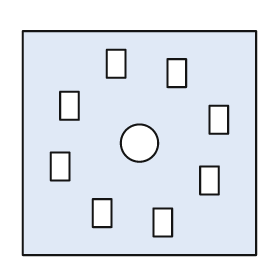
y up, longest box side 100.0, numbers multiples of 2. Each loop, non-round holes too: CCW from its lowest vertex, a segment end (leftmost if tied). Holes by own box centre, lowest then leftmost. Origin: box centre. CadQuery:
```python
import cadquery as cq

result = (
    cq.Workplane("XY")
    .moveTo(-50.0, -48.0)
    .lineTo(50.0, -48.0)
    .lineTo(50.0, 48.0)
    .lineTo(-50.0, 48.0)
    .close()
    .moveTo(6.0, -40.0)
    .lineTo(14.0, -40.0)
    .lineTo(14.0, -28.0)
    .lineTo(6.0, -28.0)
    .close()
    .moveTo(-20.0, -36.0)
    .lineTo(-12.0, -36.0)
    .lineTo(-12.0, -24.0)
    .lineTo(-20.0, -24.0)
    .close()
    .moveTo(26.0, -22.0)
    .lineTo(34.0, -22.0)
    .lineTo(34.0, -10.0)
    .lineTo(26.0, -10.0)
    .close()
    .moveTo(-38.0, -16.0)
    .lineTo(-30.0, -16.0)
    .lineTo(-30.0, -4.0)
    .lineTo(-38.0, -4.0)
    .close()
    .moveTo(0.0, 0.0)
    .circle(8.0)
    .moveTo(30.0, 4.0)
    .lineTo(38.0, 4.0)
    .lineTo(38.0, 16.0)
    .lineTo(30.0, 16.0)
    .close()
    .moveTo(-34.0, 10.0)
    .lineTo(-26.0, 10.0)
    .lineTo(-26.0, 22.0)
    .lineTo(-34.0, 22.0)
    .close()
    .moveTo(12.0, 24.0)
    .lineTo(20.0, 24.0)
    .lineTo(20.0, 36.0)
    .lineTo(12.0, 36.0)
    .close()
    .moveTo(-14.0, 28.0)
    .lineTo(-6.0, 28.0)
    .lineTo(-6.0, 40.0)
    .lineTo(-14.0, 40.0)
    .close()
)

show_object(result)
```